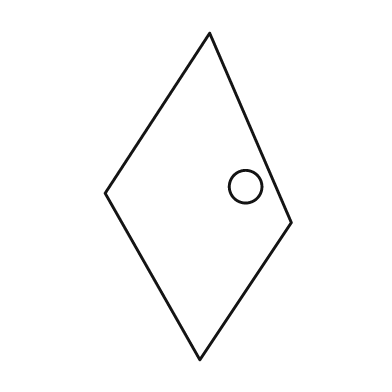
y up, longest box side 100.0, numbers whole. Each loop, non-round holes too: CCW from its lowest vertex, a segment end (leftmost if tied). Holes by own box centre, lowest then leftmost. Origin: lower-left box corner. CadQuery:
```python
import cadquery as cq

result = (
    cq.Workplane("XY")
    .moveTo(29.0, 0.0)
    .lineTo(57.0, 42.0)
    .lineTo(32.0, 100.0)
    .lineTo(0.0, 51.0)
    .close()
    .moveTo(43.0, 53.0)
    .circle(5.0)
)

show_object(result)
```